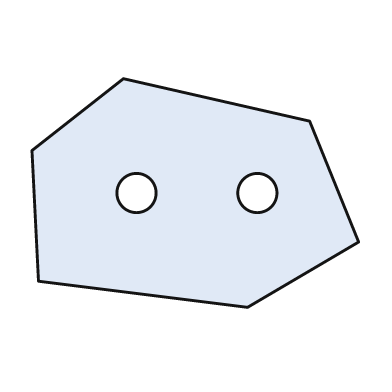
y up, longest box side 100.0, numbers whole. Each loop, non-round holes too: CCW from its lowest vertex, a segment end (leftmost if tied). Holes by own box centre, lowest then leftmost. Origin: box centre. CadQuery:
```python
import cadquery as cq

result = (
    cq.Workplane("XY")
    .moveTo(16.0, -35.0)
    .lineTo(50.0, -15.0)
    .lineTo(35.0, 22.0)
    .lineTo(-22.0, 35.0)
    .lineTo(-50.0, 13.0)
    .lineTo(-48.0, -27.0)
    .close()
    .moveTo(-18.0, 0.0)
    .circle(6.0)
    .moveTo(19.0, 0.0)
    .circle(6.0)
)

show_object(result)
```